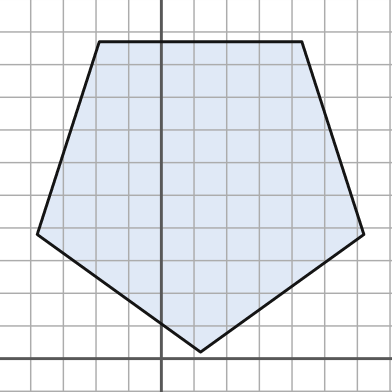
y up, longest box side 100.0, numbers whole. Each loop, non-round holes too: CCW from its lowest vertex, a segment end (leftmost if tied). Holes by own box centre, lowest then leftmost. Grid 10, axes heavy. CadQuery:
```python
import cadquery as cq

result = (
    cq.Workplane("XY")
    .moveTo(12.0, 2.0)
    .lineTo(62.0, 38.0)
    .lineTo(43.0, 97.0)
    .lineTo(-19.0, 97.0)
    .lineTo(-38.0, 38.0)
    .close()
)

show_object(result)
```